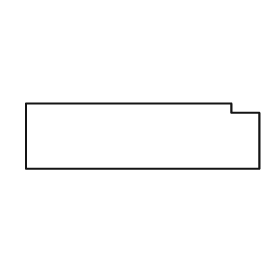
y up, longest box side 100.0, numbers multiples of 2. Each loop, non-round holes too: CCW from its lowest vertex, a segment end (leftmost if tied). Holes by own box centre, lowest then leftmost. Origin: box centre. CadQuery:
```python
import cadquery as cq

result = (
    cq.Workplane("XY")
    .moveTo(-50.0, -14.0)
    .lineTo(50.0, -14.0)
    .lineTo(50.0, 10.0)
    .lineTo(38.0, 10.0)
    .lineTo(38.0, 14.0)
    .lineTo(-50.0, 14.0)
    .close()
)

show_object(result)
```